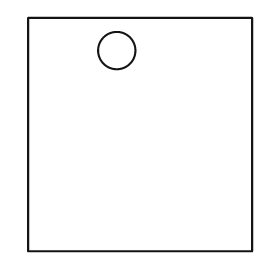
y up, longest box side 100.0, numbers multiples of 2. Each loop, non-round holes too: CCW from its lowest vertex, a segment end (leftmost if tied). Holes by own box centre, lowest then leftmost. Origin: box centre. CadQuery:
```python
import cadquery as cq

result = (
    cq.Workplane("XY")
    .moveTo(-48.0, -50.0)
    .lineTo(48.0, -50.0)
    .lineTo(48.0, 50.0)
    .lineTo(-48.0, 50.0)
    .close()
    .moveTo(-10.0, 36.0)
    .circle(8.0)
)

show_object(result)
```